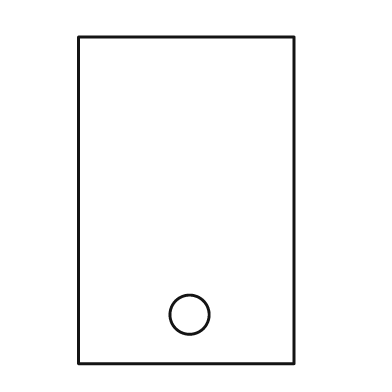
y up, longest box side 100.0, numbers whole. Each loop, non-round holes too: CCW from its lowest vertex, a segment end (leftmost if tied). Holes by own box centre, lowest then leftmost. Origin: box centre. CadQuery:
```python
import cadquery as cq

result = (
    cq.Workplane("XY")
    .moveTo(-33.0, -50.0)
    .lineTo(33.0, -50.0)
    .lineTo(33.0, 50.0)
    .lineTo(-33.0, 50.0)
    .close()
    .moveTo(1.0, -35.0)
    .circle(6.0)
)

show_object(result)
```